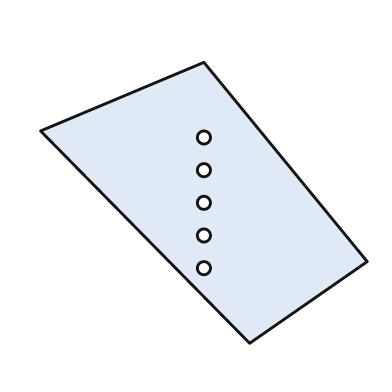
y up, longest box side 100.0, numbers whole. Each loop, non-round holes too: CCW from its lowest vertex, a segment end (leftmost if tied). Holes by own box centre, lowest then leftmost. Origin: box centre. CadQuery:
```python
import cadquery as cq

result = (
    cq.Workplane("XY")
    .moveTo(14.0, -43.0)
    .lineTo(50.0, -18.0)
    .lineTo(0.0, 43.0)
    .lineTo(-50.0, 22.0)
    .close()
    .moveTo(0.0, -20.0)
    .circle(2.0)
    .moveTo(0.0, -10.0)
    .circle(2.0)
    .moveTo(0.0, 0.0)
    .circle(2.0)
    .moveTo(0.0, 10.0)
    .circle(2.0)
    .moveTo(0.0, 20.0)
    .circle(2.0)
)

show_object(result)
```